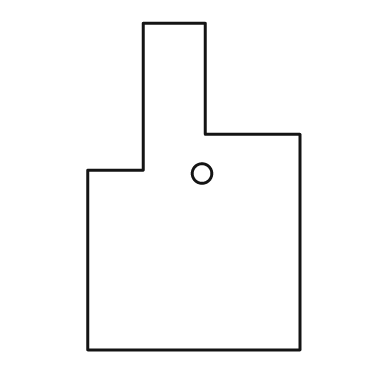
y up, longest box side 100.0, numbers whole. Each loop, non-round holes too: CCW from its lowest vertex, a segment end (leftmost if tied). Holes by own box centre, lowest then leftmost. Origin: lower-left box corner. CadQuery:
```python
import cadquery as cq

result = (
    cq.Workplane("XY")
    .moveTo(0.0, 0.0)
    .lineTo(65.0, 0.0)
    .lineTo(65.0, 66.0)
    .lineTo(36.0, 66.0)
    .lineTo(36.0, 100.0)
    .lineTo(17.0, 100.0)
    .lineTo(17.0, 55.0)
    .lineTo(0.0, 55.0)
    .close()
    .moveTo(35.0, 54.0)
    .circle(3.0)
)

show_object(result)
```